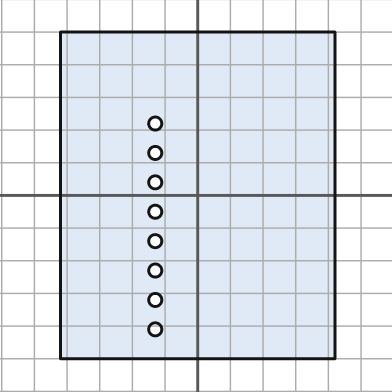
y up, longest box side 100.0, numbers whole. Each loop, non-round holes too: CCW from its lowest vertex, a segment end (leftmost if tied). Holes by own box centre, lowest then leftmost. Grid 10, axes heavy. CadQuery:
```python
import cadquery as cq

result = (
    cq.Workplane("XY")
    .moveTo(-42.0, -50.0)
    .lineTo(42.0, -50.0)
    .lineTo(42.0, 50.0)
    .lineTo(-42.0, 50.0)
    .close()
    .moveTo(-13.0, -41.0)
    .circle(2.0)
    .moveTo(-13.0, -32.0)
    .circle(2.0)
    .moveTo(-13.0, -23.0)
    .circle(2.0)
    .moveTo(-13.0, -14.0)
    .circle(2.0)
    .moveTo(-13.0, -5.0)
    .circle(2.0)
    .moveTo(-13.0, 4.0)
    .circle(2.0)
    .moveTo(-13.0, 13.0)
    .circle(2.0)
    .moveTo(-13.0, 22.0)
    .circle(2.0)
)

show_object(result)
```